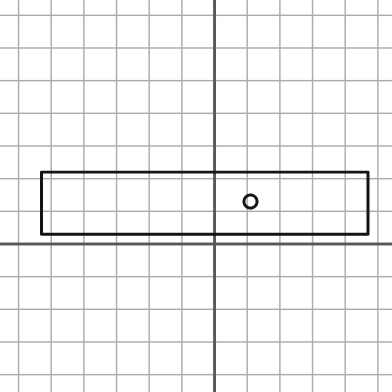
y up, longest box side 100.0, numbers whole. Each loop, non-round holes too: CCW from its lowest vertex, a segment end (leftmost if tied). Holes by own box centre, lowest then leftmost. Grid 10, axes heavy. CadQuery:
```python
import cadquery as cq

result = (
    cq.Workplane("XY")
    .moveTo(-53.0, 3.0)
    .lineTo(47.0, 3.0)
    .lineTo(47.0, 22.0)
    .lineTo(-53.0, 22.0)
    .close()
    .moveTo(11.0, 13.0)
    .circle(2.0)
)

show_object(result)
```